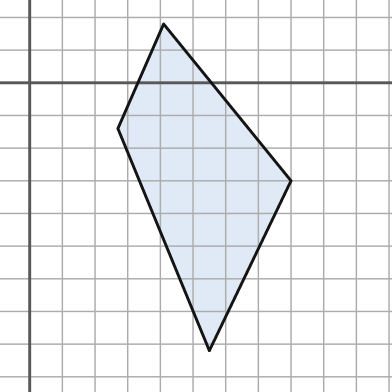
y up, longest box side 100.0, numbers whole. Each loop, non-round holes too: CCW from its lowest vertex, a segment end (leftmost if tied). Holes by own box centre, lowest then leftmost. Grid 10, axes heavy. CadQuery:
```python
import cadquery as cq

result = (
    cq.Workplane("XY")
    .moveTo(55.0, -82.0)
    .lineTo(80.0, -30.0)
    .lineTo(41.0, 18.0)
    .lineTo(27.0, -14.0)
    .close()
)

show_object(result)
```